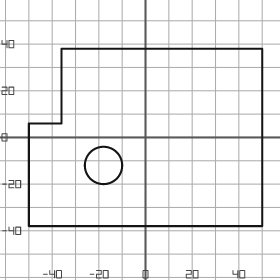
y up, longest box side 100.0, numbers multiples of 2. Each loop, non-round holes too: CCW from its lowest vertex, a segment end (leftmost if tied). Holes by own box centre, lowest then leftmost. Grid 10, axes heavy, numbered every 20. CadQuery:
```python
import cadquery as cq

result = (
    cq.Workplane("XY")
    .moveTo(-50.0, -38.0)
    .lineTo(50.0, -38.0)
    .lineTo(50.0, 38.0)
    .lineTo(-36.0, 38.0)
    .lineTo(-36.0, 6.0)
    .lineTo(-50.0, 6.0)
    .close()
    .moveTo(-18.0, -12.0)
    .circle(8.0)
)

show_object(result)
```